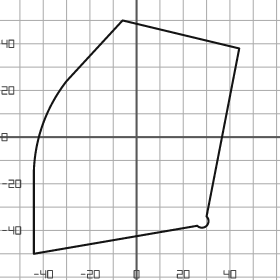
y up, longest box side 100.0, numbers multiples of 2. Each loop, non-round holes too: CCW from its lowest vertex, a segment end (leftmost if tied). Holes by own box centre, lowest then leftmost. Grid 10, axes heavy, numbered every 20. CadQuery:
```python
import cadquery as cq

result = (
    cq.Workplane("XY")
    .moveTo(-44.0, -50.0)
    .lineTo(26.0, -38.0)
    .threePointArc((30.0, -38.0), (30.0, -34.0))
    .lineTo(44.0, 38.0)
    .lineTo(-6.0, 50.0)
    .lineTo(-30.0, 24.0)
    .threePointArc((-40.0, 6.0), (-44.0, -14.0))
    .close()
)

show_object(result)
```